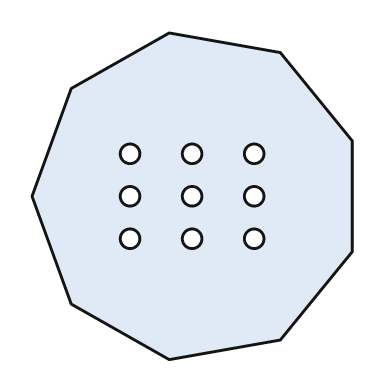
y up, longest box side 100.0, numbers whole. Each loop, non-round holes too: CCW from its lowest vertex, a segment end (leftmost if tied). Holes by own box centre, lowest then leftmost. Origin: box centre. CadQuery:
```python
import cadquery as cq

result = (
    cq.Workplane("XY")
    .moveTo(-7.0, -50.0)
    .lineTo(27.0, -44.0)
    .lineTo(49.0, -17.0)
    .lineTo(49.0, 17.0)
    .lineTo(27.0, 44.0)
    .lineTo(-7.0, 50.0)
    .lineTo(-37.0, 33.0)
    .lineTo(-49.0, 0.0)
    .lineTo(-37.0, -33.0)
    .close()
    .moveTo(-19.0, -13.0)
    .circle(3.0)
    .moveTo(0.0, -13.0)
    .circle(3.0)
    .moveTo(19.0, -13.0)
    .circle(3.0)
    .moveTo(-19.0, 0.0)
    .circle(3.0)
    .moveTo(0.0, 0.0)
    .circle(3.0)
    .moveTo(19.0, 0.0)
    .circle(3.0)
    .moveTo(-19.0, 13.0)
    .circle(3.0)
    .moveTo(0.0, 13.0)
    .circle(3.0)
    .moveTo(19.0, 13.0)
    .circle(3.0)
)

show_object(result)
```